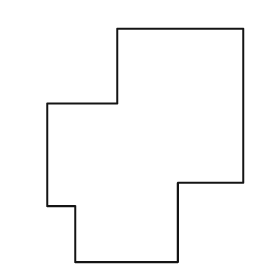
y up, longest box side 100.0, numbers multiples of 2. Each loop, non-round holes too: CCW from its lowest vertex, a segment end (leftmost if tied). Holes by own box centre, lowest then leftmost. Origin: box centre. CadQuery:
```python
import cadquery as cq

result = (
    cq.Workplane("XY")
    .moveTo(-30.0, -50.0)
    .lineTo(14.0, -50.0)
    .lineTo(14.0, -16.0)
    .lineTo(42.0, -16.0)
    .lineTo(42.0, 50.0)
    .lineTo(-12.0, 50.0)
    .lineTo(-12.0, 18.0)
    .lineTo(-42.0, 18.0)
    .lineTo(-42.0, -26.0)
    .lineTo(-30.0, -26.0)
    .close()
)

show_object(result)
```